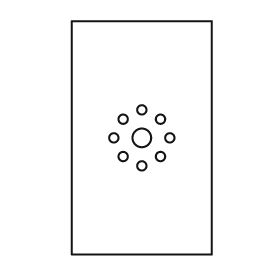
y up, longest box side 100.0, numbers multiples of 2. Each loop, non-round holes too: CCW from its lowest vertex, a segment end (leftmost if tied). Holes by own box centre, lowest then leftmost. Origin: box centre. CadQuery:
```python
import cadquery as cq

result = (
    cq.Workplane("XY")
    .moveTo(-30.0, -50.0)
    .lineTo(30.0, -50.0)
    .lineTo(30.0, 50.0)
    .lineTo(-30.0, 50.0)
    .close()
    .moveTo(0.0, -12.0)
    .circle(2.0)
    .moveTo(-8.0, -8.0)
    .circle(2.0)
    .moveTo(8.0, -8.0)
    .circle(2.0)
    .moveTo(-12.0, 0.0)
    .circle(2.0)
    .moveTo(0.0, 0.0)
    .circle(4.0)
    .moveTo(12.0, 0.0)
    .circle(2.0)
    .moveTo(-8.0, 8.0)
    .circle(2.0)
    .moveTo(8.0, 8.0)
    .circle(2.0)
    .moveTo(0.0, 12.0)
    .circle(2.0)
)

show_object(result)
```